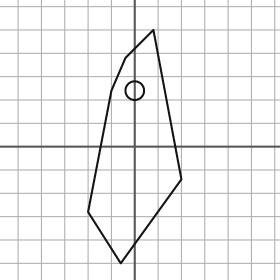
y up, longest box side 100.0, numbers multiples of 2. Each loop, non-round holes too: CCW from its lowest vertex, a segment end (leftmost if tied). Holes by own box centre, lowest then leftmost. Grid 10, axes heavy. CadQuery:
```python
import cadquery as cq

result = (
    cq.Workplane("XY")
    .moveTo(-6.0, -50.0)
    .lineTo(20.0, -14.0)
    .lineTo(8.0, 50.0)
    .lineTo(-4.0, 38.0)
    .lineTo(-10.0, 24.0)
    .lineTo(-20.0, -28.0)
    .close()
    .moveTo(0.0, 24.0)
    .circle(4.0)
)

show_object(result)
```